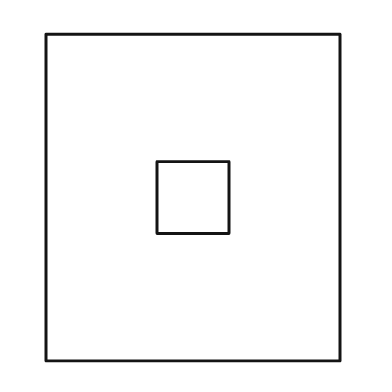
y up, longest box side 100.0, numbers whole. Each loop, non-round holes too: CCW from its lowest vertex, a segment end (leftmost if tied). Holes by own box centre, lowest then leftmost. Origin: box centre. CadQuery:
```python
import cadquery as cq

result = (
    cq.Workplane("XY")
    .moveTo(-45.0, -50.0)
    .lineTo(45.0, -50.0)
    .lineTo(45.0, 50.0)
    .lineTo(-45.0, 50.0)
    .close()
    .moveTo(-11.0, -11.0)
    .lineTo(11.0, -11.0)
    .lineTo(11.0, 11.0)
    .lineTo(-11.0, 11.0)
    .close()
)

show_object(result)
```